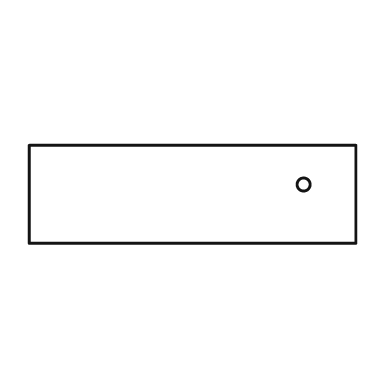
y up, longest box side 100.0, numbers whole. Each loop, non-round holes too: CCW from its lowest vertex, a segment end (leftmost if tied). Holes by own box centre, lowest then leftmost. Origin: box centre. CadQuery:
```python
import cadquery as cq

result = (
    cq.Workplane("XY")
    .moveTo(-50.0, -15.0)
    .lineTo(50.0, -15.0)
    .lineTo(50.0, 15.0)
    .lineTo(-50.0, 15.0)
    .close()
    .moveTo(34.0, 3.0)
    .circle(2.0)
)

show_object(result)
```